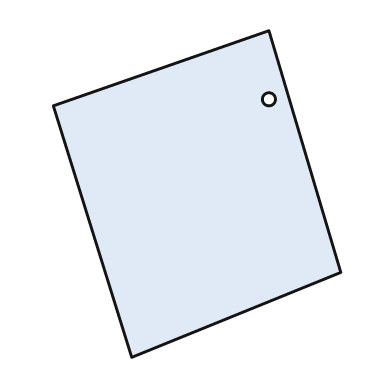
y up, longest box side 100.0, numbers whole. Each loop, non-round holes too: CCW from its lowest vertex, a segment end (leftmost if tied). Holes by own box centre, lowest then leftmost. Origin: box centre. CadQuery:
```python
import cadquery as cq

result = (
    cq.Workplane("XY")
    .moveTo(-20.0, -50.0)
    .lineTo(44.0, -24.0)
    .lineTo(22.0, 50.0)
    .lineTo(-44.0, 27.0)
    .close()
    .moveTo(22.0, 29.0)
    .circle(2.0)
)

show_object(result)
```